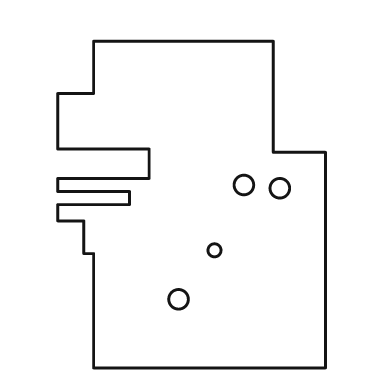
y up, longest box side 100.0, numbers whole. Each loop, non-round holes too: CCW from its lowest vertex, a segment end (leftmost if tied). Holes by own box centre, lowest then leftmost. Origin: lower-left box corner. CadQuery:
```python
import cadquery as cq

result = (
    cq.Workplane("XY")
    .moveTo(11.0, 0.0)
    .lineTo(82.0, 0.0)
    .lineTo(82.0, 66.0)
    .lineTo(66.0, 66.0)
    .lineTo(66.0, 100.0)
    .lineTo(11.0, 100.0)
    .lineTo(11.0, 84.0)
    .lineTo(0.0, 84.0)
    .lineTo(0.0, 67.0)
    .lineTo(28.0, 67.0)
    .lineTo(28.0, 58.0)
    .lineTo(0.0, 58.0)
    .lineTo(0.0, 54.0)
    .lineTo(22.0, 54.0)
    .lineTo(22.0, 50.0)
    .lineTo(0.0, 50.0)
    .lineTo(0.0, 45.0)
    .lineTo(8.0, 45.0)
    .lineTo(8.0, 35.0)
    .lineTo(11.0, 35.0)
    .close()
    .moveTo(37.0, 21.0)
    .circle(3.0)
    .moveTo(48.0, 36.0)
    .circle(2.0)
    .moveTo(68.0, 55.0)
    .circle(3.0)
    .moveTo(57.0, 56.0)
    .circle(3.0)
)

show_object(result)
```